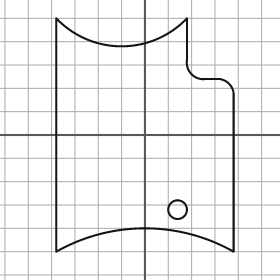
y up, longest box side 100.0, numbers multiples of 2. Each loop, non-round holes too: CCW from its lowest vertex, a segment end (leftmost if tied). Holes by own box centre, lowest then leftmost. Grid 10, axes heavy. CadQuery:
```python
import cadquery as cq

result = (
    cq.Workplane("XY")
    .moveTo(-38.0, -50.0)
    .threePointArc((0.0, -40.0), (38.0, -50.0))
    .lineTo(38.0, 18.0)
    .threePointArc((36.0, 22.0), (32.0, 24.0))
    .lineTo(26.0, 24.0)
    .threePointArc((20.0, 26.0), (18.0, 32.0))
    .lineTo(18.0, 50.0)
    .threePointArc((-10.0, 38.0), (-38.0, 50.0))
    .close()
    .moveTo(14.0, -32.0)
    .circle(4.0)
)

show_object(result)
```